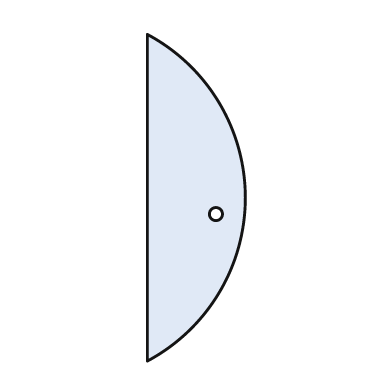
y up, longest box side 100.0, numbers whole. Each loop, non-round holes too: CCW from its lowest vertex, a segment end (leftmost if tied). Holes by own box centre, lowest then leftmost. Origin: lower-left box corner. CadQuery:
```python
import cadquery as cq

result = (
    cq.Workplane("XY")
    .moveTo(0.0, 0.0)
    .threePointArc((30.0, 50.0), (0.0, 100.0))
    .close()
    .moveTo(21.0, 45.0)
    .circle(2.0)
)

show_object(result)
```